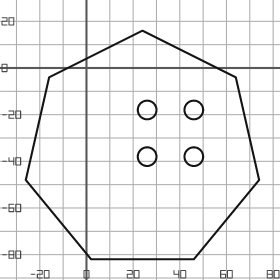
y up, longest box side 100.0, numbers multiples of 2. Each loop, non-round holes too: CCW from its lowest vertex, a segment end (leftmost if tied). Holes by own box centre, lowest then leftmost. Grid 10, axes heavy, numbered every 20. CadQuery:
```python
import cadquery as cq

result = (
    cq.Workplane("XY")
    .moveTo(2.0, -82.0)
    .lineTo(46.0, -82.0)
    .lineTo(74.0, -48.0)
    .lineTo(64.0, -4.0)
    .lineTo(24.0, 16.0)
    .lineTo(-16.0, -4.0)
    .lineTo(-26.0, -48.0)
    .close()
    .moveTo(26.0, -38.0)
    .circle(4.0)
    .moveTo(46.0, -38.0)
    .circle(4.0)
    .moveTo(26.0, -18.0)
    .circle(4.0)
    .moveTo(46.0, -18.0)
    .circle(4.0)
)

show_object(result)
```